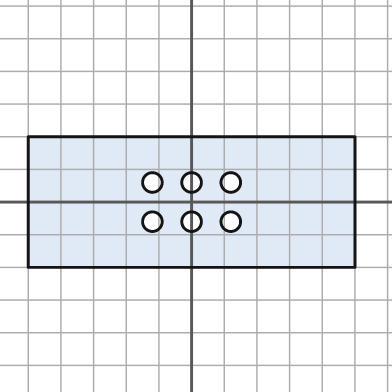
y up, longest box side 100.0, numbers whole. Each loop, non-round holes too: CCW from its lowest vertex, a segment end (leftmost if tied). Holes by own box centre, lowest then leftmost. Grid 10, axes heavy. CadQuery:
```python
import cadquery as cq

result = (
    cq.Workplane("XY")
    .moveTo(-50.0, -20.0)
    .lineTo(50.0, -20.0)
    .lineTo(50.0, 20.0)
    .lineTo(-50.0, 20.0)
    .close()
    .moveTo(-12.0, -6.0)
    .circle(3.0)
    .moveTo(0.0, -6.0)
    .circle(3.0)
    .moveTo(12.0, -6.0)
    .circle(3.0)
    .moveTo(-12.0, 6.0)
    .circle(3.0)
    .moveTo(0.0, 6.0)
    .circle(3.0)
    .moveTo(12.0, 6.0)
    .circle(3.0)
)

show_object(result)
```